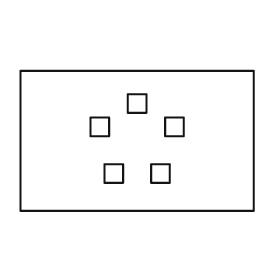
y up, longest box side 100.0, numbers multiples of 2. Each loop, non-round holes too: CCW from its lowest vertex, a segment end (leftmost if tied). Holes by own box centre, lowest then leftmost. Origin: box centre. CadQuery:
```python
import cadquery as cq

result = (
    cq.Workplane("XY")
    .moveTo(-50.0, -30.0)
    .lineTo(50.0, -30.0)
    .lineTo(50.0, 30.0)
    .lineTo(-50.0, 30.0)
    .close()
    .moveTo(-14.0, -18.0)
    .lineTo(-6.0, -18.0)
    .lineTo(-6.0, -10.0)
    .lineTo(-14.0, -10.0)
    .close()
    .moveTo(6.0, -18.0)
    .lineTo(14.0, -18.0)
    .lineTo(14.0, -10.0)
    .lineTo(6.0, -10.0)
    .close()
    .moveTo(-20.0, 2.0)
    .lineTo(-12.0, 2.0)
    .lineTo(-12.0, 10.0)
    .lineTo(-20.0, 10.0)
    .close()
    .moveTo(12.0, 2.0)
    .lineTo(20.0, 2.0)
    .lineTo(20.0, 10.0)
    .lineTo(12.0, 10.0)
    .close()
    .moveTo(-4.0, 12.0)
    .lineTo(4.0, 12.0)
    .lineTo(4.0, 20.0)
    .lineTo(-4.0, 20.0)
    .close()
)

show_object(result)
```